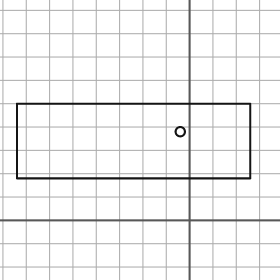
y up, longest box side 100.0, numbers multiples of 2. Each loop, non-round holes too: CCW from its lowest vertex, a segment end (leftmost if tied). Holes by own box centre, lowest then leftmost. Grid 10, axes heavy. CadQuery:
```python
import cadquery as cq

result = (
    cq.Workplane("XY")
    .moveTo(-74.0, 18.0)
    .lineTo(26.0, 18.0)
    .lineTo(26.0, 50.0)
    .lineTo(-74.0, 50.0)
    .close()
    .moveTo(-4.0, 38.0)
    .circle(2.0)
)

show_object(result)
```